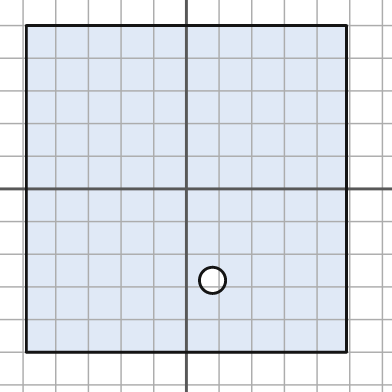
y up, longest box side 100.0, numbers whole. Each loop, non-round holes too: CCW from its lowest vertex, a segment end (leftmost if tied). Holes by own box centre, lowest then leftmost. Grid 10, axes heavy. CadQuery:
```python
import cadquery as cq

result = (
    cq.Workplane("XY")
    .moveTo(-49.0, -50.0)
    .lineTo(49.0, -50.0)
    .lineTo(49.0, 50.0)
    .lineTo(-49.0, 50.0)
    .close()
    .moveTo(8.0, -28.0)
    .circle(4.0)
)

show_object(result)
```